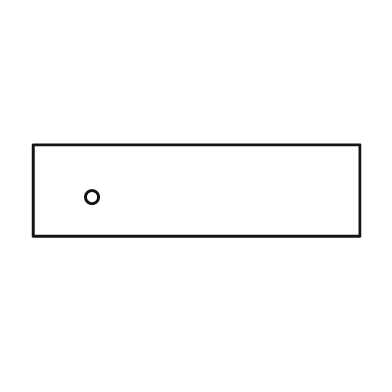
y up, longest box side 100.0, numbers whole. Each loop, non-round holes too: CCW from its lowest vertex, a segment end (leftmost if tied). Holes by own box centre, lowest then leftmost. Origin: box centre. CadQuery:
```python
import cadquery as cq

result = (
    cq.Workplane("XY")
    .moveTo(-50.0, -14.0)
    .lineTo(50.0, -14.0)
    .lineTo(50.0, 14.0)
    .lineTo(-50.0, 14.0)
    .close()
    .moveTo(-32.0, -2.0)
    .circle(2.0)
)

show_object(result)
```